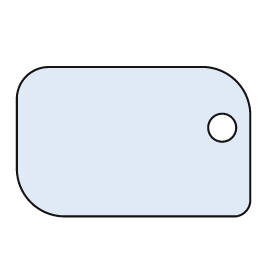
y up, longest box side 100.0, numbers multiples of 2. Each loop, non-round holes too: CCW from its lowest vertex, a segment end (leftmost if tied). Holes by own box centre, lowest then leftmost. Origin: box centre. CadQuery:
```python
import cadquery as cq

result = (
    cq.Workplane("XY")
    .moveTo(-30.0, -32.0)
    .lineTo(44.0, -32.0)
    .threePointArc((48.0, -30.0), (50.0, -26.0))
    .lineTo(50.0, 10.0)
    .threePointArc((44.0, 26.0), (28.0, 32.0))
    .lineTo(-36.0, 32.0)
    .threePointArc((-46.0, 28.0), (-50.0, 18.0))
    .lineTo(-50.0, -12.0)
    .threePointArc((-44.0, -26.0), (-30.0, -32.0))
    .close()
    .moveTo(38.0, 6.0)
    .circle(6.0)
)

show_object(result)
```